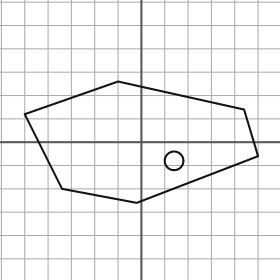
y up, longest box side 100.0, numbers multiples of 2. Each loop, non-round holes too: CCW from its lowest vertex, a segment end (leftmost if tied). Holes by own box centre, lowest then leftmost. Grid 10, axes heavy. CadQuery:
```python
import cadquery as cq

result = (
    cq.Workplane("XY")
    .moveTo(-2.0, -26.0)
    .lineTo(50.0, -6.0)
    .lineTo(44.0, 14.0)
    .lineTo(-10.0, 26.0)
    .lineTo(-50.0, 12.0)
    .lineTo(-34.0, -20.0)
    .close()
    .moveTo(14.0, -8.0)
    .circle(4.0)
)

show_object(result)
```